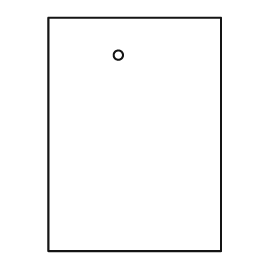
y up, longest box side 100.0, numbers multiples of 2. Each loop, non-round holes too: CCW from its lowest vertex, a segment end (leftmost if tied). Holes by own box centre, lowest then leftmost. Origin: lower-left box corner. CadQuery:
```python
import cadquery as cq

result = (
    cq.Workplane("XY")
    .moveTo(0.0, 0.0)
    .lineTo(74.0, 0.0)
    .lineTo(74.0, 100.0)
    .lineTo(0.0, 100.0)
    .close()
    .moveTo(30.0, 84.0)
    .circle(2.0)
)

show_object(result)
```